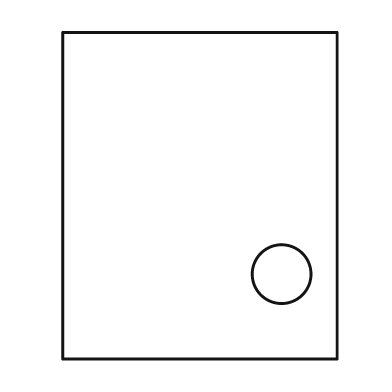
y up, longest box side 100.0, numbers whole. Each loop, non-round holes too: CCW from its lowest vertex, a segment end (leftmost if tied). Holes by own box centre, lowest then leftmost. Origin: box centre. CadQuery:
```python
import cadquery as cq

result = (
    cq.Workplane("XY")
    .moveTo(-42.0, -50.0)
    .lineTo(42.0, -50.0)
    .lineTo(42.0, 50.0)
    .lineTo(-42.0, 50.0)
    .close()
    .moveTo(25.0, -24.0)
    .circle(9.0)
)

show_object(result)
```